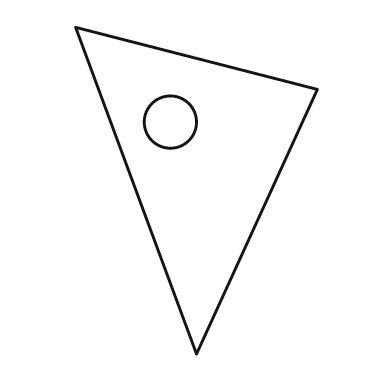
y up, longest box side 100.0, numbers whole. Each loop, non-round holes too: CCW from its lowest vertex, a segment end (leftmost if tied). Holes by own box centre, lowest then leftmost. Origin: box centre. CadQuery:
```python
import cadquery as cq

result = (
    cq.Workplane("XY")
    .moveTo(0.0, -50.0)
    .lineTo(37.0, 31.0)
    .lineTo(-37.0, 50.0)
    .close()
    .moveTo(-8.0, 21.0)
    .circle(8.0)
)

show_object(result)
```